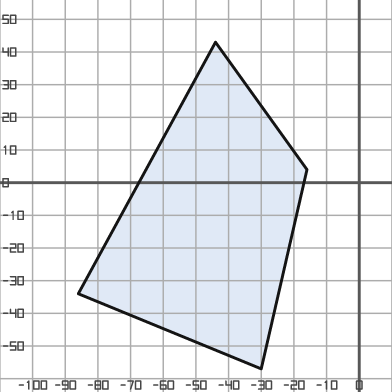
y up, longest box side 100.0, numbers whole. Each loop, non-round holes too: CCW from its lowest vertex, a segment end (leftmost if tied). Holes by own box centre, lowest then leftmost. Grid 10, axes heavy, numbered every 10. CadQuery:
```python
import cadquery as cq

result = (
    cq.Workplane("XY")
    .moveTo(-30.0, -57.0)
    .lineTo(-16.0, 4.0)
    .lineTo(-44.0, 43.0)
    .lineTo(-86.0, -34.0)
    .close()
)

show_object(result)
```